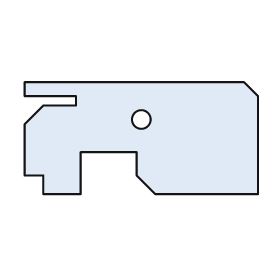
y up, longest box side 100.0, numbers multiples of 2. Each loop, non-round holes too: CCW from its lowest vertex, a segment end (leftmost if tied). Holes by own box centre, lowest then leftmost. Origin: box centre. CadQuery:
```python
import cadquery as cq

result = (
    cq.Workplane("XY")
    .moveTo(-42.0, -24.0)
    .lineTo(-26.0, -24.0)
    .lineTo(-26.0, -6.0)
    .lineTo(-2.0, -6.0)
    .lineTo(-2.0, -16.0)
    .lineTo(6.0, -24.0)
    .lineTo(50.0, -24.0)
    .lineTo(50.0, 18.0)
    .lineTo(44.0, 24.0)
    .lineTo(-50.0, 24.0)
    .lineTo(-50.0, 18.0)
    .lineTo(-28.0, 18.0)
    .lineTo(-28.0, 14.0)
    .lineTo(-42.0, 14.0)
    .lineTo(-50.0, 6.0)
    .lineTo(-50.0, -16.0)
    .lineTo(-42.0, -16.0)
    .close()
    .moveTo(0.0, 8.0)
    .circle(4.0)
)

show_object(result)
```